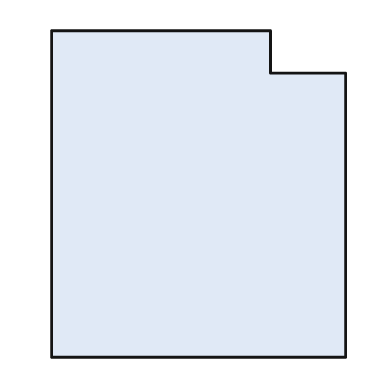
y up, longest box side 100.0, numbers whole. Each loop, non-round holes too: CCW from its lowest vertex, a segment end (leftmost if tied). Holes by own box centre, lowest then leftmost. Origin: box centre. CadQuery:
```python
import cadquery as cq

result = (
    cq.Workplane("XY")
    .moveTo(-45.0, -50.0)
    .lineTo(45.0, -50.0)
    .lineTo(45.0, 37.0)
    .lineTo(22.0, 37.0)
    .lineTo(22.0, 50.0)
    .lineTo(-45.0, 50.0)
    .close()
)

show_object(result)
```